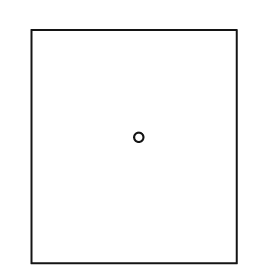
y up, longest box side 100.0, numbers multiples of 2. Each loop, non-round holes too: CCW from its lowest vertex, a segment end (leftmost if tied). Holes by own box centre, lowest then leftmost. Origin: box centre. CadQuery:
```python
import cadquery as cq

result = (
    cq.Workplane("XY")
    .moveTo(-44.0, -50.0)
    .lineTo(44.0, -50.0)
    .lineTo(44.0, 50.0)
    .lineTo(-44.0, 50.0)
    .close()
    .moveTo(2.0, 4.0)
    .circle(2.0)
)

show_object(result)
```